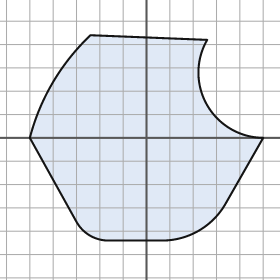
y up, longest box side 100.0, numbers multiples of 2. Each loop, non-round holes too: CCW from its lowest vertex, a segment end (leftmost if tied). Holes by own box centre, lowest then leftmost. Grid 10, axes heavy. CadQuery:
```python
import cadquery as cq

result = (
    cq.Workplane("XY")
    .moveTo(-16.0, -44.0)
    .lineTo(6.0, -44.0)
    .threePointArc((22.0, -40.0), (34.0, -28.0))
    .lineTo(50.0, 0.0)
    .threePointArc((26.0, 14.0), (26.0, 42.0))
    .lineTo(-24.0, 44.0)
    .threePointArc((-40.0, 24.0), (-50.0, 0.0))
    .lineTo(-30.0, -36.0)
    .threePointArc((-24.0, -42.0), (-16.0, -44.0))
    .close()
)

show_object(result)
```